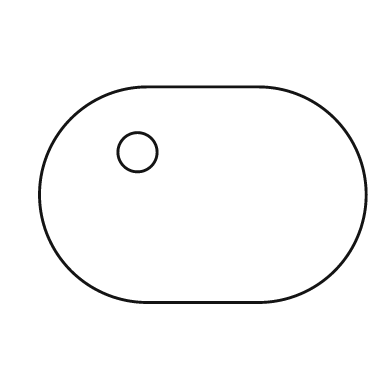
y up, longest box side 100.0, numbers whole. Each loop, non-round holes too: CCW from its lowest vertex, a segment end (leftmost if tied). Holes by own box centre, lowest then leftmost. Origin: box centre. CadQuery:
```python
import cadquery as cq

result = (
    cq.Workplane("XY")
    .moveTo(-17.0, -33.0)
    .lineTo(17.0, -33.0)
    .threePointArc((50.0, 0.0), (17.0, 33.0))
    .lineTo(-17.0, 33.0)
    .threePointArc((-50.0, 0.0), (-17.0, -33.0))
    .close()
    .moveTo(-20.0, 13.0)
    .circle(6.0)
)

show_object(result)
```